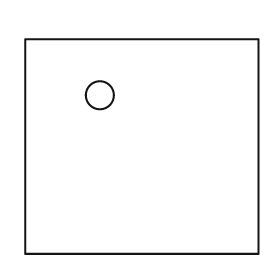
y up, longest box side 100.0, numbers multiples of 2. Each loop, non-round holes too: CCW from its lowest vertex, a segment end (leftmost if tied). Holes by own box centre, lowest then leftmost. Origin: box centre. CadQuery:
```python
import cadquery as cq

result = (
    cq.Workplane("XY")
    .moveTo(-50.0, -46.0)
    .lineTo(50.0, -46.0)
    .lineTo(50.0, 46.0)
    .lineTo(-50.0, 46.0)
    .close()
    .moveTo(-18.0, 22.0)
    .circle(6.0)
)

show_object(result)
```